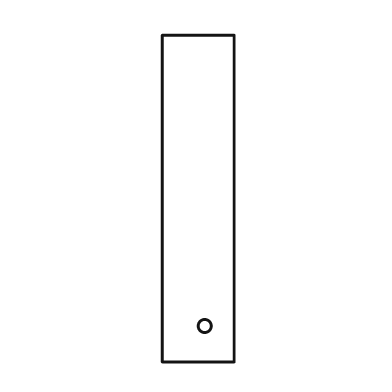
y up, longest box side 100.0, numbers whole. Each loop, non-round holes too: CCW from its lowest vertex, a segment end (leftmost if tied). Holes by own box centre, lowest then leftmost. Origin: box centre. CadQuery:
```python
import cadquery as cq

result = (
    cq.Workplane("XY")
    .moveTo(-11.0, -50.0)
    .lineTo(11.0, -50.0)
    .lineTo(11.0, 50.0)
    .lineTo(-11.0, 50.0)
    .close()
    .moveTo(2.0, -39.0)
    .circle(2.0)
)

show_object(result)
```